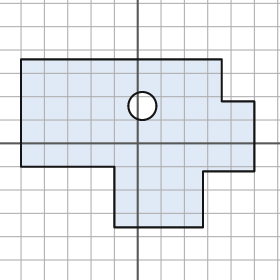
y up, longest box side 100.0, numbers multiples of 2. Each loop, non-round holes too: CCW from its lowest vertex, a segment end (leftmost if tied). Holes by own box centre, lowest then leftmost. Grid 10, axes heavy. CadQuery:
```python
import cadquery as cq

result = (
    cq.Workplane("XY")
    .moveTo(-10.0, -36.0)
    .lineTo(28.0, -36.0)
    .lineTo(28.0, -12.0)
    .lineTo(50.0, -12.0)
    .lineTo(50.0, 18.0)
    .lineTo(36.0, 18.0)
    .lineTo(36.0, 36.0)
    .lineTo(-50.0, 36.0)
    .lineTo(-50.0, -10.0)
    .lineTo(-10.0, -10.0)
    .close()
    .moveTo(2.0, 16.0)
    .circle(6.0)
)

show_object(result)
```